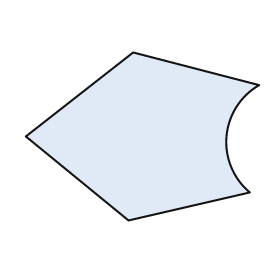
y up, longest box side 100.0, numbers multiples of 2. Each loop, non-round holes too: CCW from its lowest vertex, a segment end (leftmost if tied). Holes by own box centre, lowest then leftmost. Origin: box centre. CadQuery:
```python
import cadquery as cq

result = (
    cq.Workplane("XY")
    .moveTo(-6.0, -36.0)
    .lineTo(46.0, -24.0)
    .threePointArc((36.0, 0.0), (50.0, 22.0))
    .lineTo(-4.0, 36.0)
    .lineTo(-50.0, 0.0)
    .close()
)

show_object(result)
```